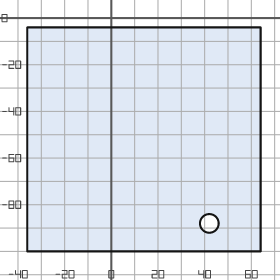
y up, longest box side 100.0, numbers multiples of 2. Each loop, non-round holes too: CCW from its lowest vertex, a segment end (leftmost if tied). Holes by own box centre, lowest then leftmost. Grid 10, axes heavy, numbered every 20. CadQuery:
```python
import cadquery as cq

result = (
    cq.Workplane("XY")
    .moveTo(-36.0, -100.0)
    .lineTo(64.0, -100.0)
    .lineTo(64.0, -4.0)
    .lineTo(-36.0, -4.0)
    .close()
    .moveTo(42.0, -88.0)
    .circle(4.0)
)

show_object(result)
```